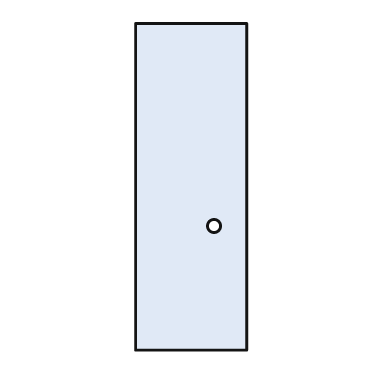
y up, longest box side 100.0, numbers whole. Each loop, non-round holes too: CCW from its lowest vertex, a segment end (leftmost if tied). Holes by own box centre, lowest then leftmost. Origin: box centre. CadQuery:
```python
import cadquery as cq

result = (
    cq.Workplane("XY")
    .moveTo(-17.0, -50.0)
    .lineTo(17.0, -50.0)
    .lineTo(17.0, 50.0)
    .lineTo(-17.0, 50.0)
    .close()
    .moveTo(7.0, -12.0)
    .circle(2.0)
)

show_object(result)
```